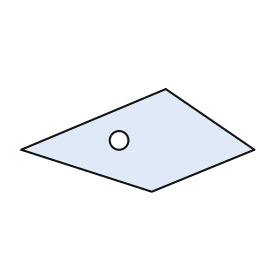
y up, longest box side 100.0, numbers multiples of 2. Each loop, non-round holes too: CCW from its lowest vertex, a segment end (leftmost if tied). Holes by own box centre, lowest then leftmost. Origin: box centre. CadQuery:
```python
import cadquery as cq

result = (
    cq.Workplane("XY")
    .moveTo(6.0, -22.0)
    .lineTo(50.0, -4.0)
    .lineTo(12.0, 22.0)
    .lineTo(-50.0, -4.0)
    .close()
    .moveTo(-8.0, 0.0)
    .circle(4.0)
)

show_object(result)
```